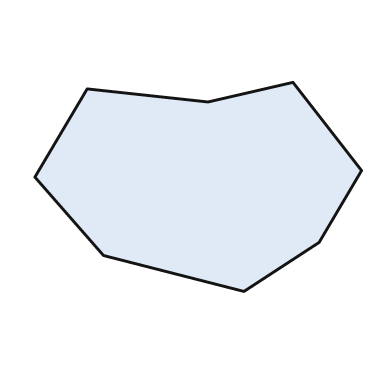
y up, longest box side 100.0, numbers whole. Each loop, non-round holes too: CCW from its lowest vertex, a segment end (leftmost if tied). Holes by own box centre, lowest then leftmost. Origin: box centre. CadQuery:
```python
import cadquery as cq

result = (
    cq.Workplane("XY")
    .moveTo(14.0, -32.0)
    .lineTo(37.0, -17.0)
    .lineTo(50.0, 5.0)
    .lineTo(29.0, 32.0)
    .lineTo(3.0, 26.0)
    .lineTo(-34.0, 30.0)
    .lineTo(-50.0, 3.0)
    .lineTo(-29.0, -21.0)
    .close()
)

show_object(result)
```